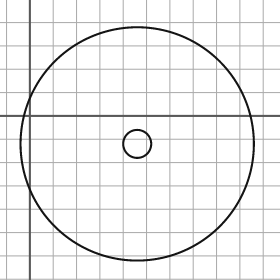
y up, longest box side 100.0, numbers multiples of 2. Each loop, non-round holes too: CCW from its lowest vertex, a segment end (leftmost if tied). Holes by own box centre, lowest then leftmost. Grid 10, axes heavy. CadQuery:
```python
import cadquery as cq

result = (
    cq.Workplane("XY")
    .moveTo(46.0, -12.0)
    .circle(50.0)
    .moveTo(46.0, -12.0)
    .circle(6.0)
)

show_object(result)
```